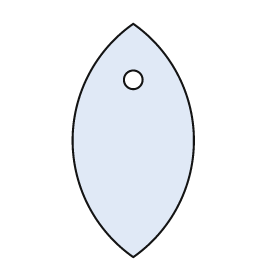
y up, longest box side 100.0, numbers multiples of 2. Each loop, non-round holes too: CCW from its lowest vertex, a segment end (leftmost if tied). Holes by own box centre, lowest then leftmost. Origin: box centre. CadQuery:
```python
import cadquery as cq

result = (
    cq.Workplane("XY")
    .moveTo(0.0, -50.0)
    .threePointArc((26.0, 0.0), (0.0, 50.0))
    .threePointArc((-26.0, 0.0), (0.0, -50.0))
    .close()
    .moveTo(0.0, 26.0)
    .circle(4.0)
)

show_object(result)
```